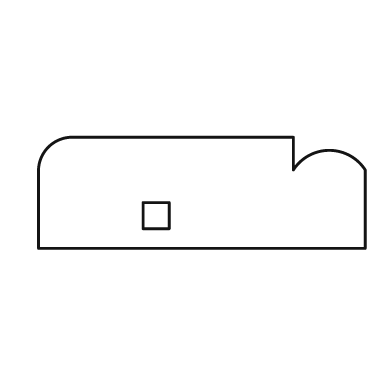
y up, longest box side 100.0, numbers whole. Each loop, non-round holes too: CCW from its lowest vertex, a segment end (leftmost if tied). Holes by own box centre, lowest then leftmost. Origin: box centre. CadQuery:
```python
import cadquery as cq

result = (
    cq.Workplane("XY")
    .moveTo(-50.0, -17.0)
    .lineTo(50.0, -17.0)
    .lineTo(50.0, 7.0)
    .threePointArc((39.0, 13.0), (28.0, 7.0))
    .lineTo(28.0, 17.0)
    .lineTo(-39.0, 17.0)
    .threePointArc((-47.0, 14.0), (-50.0, 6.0))
    .close()
    .moveTo(-18.0, -11.0)
    .lineTo(-10.0, -11.0)
    .lineTo(-10.0, -3.0)
    .lineTo(-18.0, -3.0)
    .close()
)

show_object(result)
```